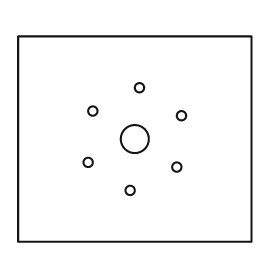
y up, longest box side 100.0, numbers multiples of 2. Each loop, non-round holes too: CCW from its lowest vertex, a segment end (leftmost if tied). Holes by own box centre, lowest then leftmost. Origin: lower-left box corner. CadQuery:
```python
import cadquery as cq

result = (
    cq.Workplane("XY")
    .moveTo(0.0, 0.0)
    .lineTo(100.0, 0.0)
    .lineTo(100.0, 88.0)
    .lineTo(0.0, 88.0)
    .close()
    .moveTo(48.0, 22.0)
    .circle(2.0)
    .moveTo(68.0, 32.0)
    .circle(2.0)
    .moveTo(30.0, 34.0)
    .circle(2.0)
    .moveTo(50.0, 44.0)
    .circle(6.0)
    .moveTo(70.0, 54.0)
    .circle(2.0)
    .moveTo(32.0, 56.0)
    .circle(2.0)
    .moveTo(52.0, 66.0)
    .circle(2.0)
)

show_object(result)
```